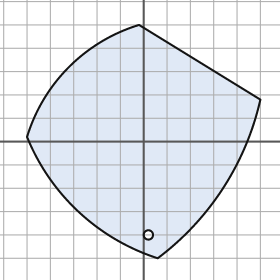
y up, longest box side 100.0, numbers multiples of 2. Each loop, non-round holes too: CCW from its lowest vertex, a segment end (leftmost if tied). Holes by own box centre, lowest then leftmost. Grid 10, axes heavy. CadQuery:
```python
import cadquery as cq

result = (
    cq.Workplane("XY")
    .moveTo(6.0, -50.0)
    .threePointArc((34.0, -20.0), (50.0, 18.0))
    .lineTo(-2.0, 50.0)
    .threePointArc((-32.0, 32.0), (-50.0, 2.0))
    .threePointArc((-28.0, -30.0), (6.0, -50.0))
    .close()
    .moveTo(2.0, -40.0)
    .circle(2.0)
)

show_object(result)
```